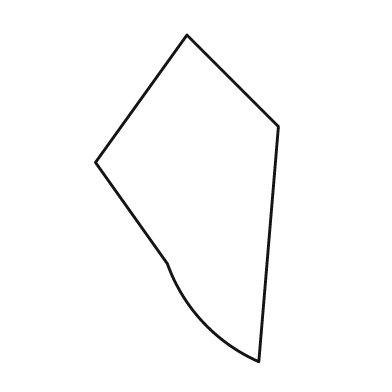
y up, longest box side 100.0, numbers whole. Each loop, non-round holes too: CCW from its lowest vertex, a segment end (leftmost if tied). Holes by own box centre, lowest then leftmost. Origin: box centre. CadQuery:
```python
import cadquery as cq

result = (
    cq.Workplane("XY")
    .moveTo(22.0, -50.0)
    .lineTo(28.0, 22.0)
    .lineTo(0.0, 50.0)
    .lineTo(-28.0, 11.0)
    .lineTo(-6.0, -20.0)
    .threePointArc((5.0, -38.0), (22.0, -50.0))
    .close()
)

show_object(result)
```